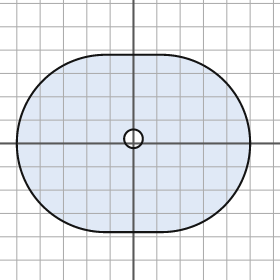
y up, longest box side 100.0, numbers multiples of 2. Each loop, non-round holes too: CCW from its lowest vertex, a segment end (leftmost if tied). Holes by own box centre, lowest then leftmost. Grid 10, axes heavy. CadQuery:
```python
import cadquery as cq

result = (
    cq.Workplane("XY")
    .moveTo(-12.0, -38.0)
    .lineTo(12.0, -38.0)
    .threePointArc((50.0, 0.0), (12.0, 38.0))
    .lineTo(-12.0, 38.0)
    .threePointArc((-50.0, 0.0), (-12.0, -38.0))
    .close()
    .moveTo(0.0, 2.0)
    .circle(4.0)
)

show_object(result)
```